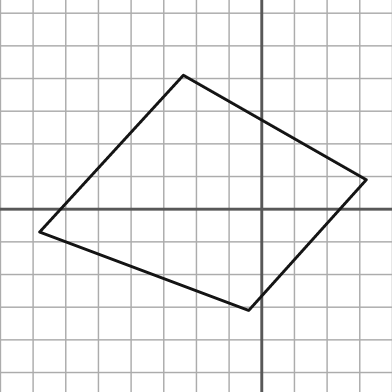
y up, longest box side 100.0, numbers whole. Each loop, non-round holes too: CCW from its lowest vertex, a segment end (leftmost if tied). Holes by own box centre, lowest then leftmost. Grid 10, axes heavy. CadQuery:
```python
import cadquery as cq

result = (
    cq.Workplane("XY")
    .moveTo(-4.0, -31.0)
    .lineTo(32.0, 9.0)
    .lineTo(-24.0, 41.0)
    .lineTo(-68.0, -7.0)
    .close()
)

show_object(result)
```